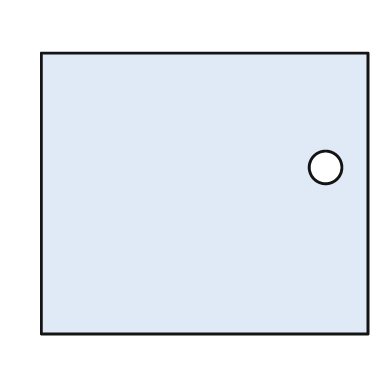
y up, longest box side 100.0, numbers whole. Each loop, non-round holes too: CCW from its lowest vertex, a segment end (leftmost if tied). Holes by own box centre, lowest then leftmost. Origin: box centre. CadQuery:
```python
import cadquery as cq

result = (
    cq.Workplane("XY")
    .moveTo(-50.0, -43.0)
    .lineTo(50.0, -43.0)
    .lineTo(50.0, 43.0)
    .lineTo(-50.0, 43.0)
    .close()
    .moveTo(37.0, 8.0)
    .circle(5.0)
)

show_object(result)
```